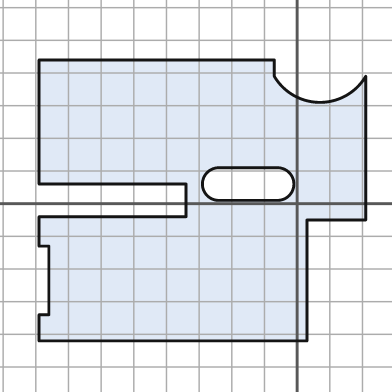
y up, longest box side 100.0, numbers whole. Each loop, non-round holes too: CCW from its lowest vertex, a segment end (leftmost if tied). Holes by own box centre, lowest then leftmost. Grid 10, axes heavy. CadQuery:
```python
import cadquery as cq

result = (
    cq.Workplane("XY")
    .moveTo(-79.0, -42.0)
    .lineTo(3.0, -42.0)
    .lineTo(3.0, -5.0)
    .lineTo(21.0, -5.0)
    .lineTo(21.0, 39.0)
    .threePointArc((7.0, 31.0), (-7.0, 39.0))
    .lineTo(-7.0, 44.0)
    .lineTo(-79.0, 44.0)
    .lineTo(-79.0, 6.0)
    .lineTo(-34.0, 6.0)
    .lineTo(-34.0, -4.0)
    .lineTo(-79.0, -4.0)
    .lineTo(-79.0, -13.0)
    .lineTo(-76.0, -13.0)
    .lineTo(-76.0, -34.0)
    .lineTo(-79.0, -34.0)
    .close()
    .moveTo(-24.0, 1.0)
    .lineTo(-6.0, 1.0)
    .threePointArc((-1.0, 6.0), (-6.0, 11.0))
    .lineTo(-24.0, 11.0)
    .threePointArc((-29.0, 6.0), (-24.0, 1.0))
    .close()
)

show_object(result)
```